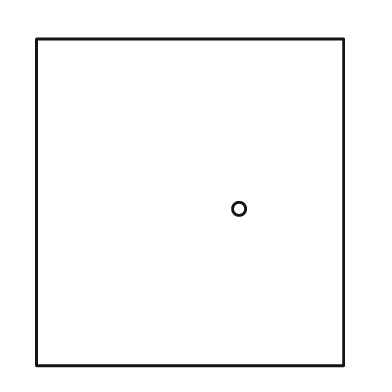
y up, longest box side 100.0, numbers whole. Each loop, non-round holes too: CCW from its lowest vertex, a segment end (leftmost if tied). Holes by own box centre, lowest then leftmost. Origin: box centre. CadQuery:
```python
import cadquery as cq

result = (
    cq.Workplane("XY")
    .moveTo(-47.0, -50.0)
    .lineTo(47.0, -50.0)
    .lineTo(47.0, 50.0)
    .lineTo(-47.0, 50.0)
    .close()
    .moveTo(15.0, -2.0)
    .circle(2.0)
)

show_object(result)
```